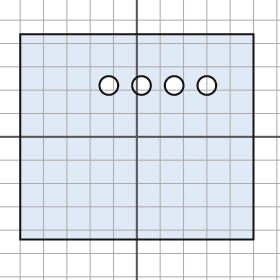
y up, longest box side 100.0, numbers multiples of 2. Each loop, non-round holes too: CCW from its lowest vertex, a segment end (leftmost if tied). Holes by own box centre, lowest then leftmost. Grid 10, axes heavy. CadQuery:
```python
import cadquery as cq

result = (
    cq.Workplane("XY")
    .moveTo(-50.0, -44.0)
    .lineTo(50.0, -44.0)
    .lineTo(50.0, 44.0)
    .lineTo(-50.0, 44.0)
    .close()
    .moveTo(-12.0, 22.0)
    .circle(4.0)
    .moveTo(2.0, 22.0)
    .circle(4.0)
    .moveTo(16.0, 22.0)
    .circle(4.0)
    .moveTo(30.0, 22.0)
    .circle(4.0)
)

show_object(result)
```